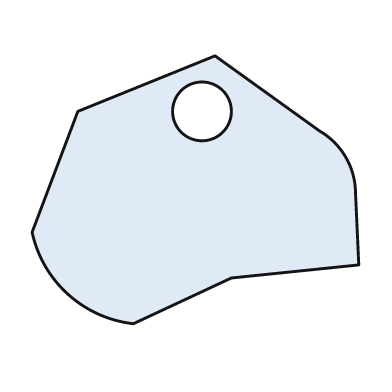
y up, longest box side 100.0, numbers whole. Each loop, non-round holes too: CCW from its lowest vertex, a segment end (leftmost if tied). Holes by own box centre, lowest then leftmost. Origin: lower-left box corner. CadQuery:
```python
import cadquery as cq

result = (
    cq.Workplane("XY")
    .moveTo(31.0, 0.0)
    .lineTo(61.0, 14.0)
    .lineTo(100.0, 18.0)
    .lineTo(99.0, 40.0)
    .threePointArc((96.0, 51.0), (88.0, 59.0))
    .lineTo(56.0, 82.0)
    .lineTo(14.0, 65.0)
    .lineTo(0.0, 28.0)
    .threePointArc((11.0, 9.0), (31.0, 0.0))
    .close()
    .moveTo(52.0, 65.0)
    .circle(9.0)
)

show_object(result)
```